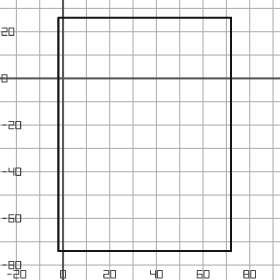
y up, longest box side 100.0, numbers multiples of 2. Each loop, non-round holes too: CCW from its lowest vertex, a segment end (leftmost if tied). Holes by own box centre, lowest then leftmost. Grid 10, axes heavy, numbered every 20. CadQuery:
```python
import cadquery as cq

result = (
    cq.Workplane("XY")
    .moveTo(-2.0, -74.0)
    .lineTo(72.0, -74.0)
    .lineTo(72.0, 26.0)
    .lineTo(-2.0, 26.0)
    .close()
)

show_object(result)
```